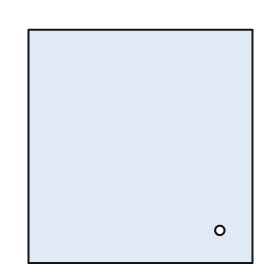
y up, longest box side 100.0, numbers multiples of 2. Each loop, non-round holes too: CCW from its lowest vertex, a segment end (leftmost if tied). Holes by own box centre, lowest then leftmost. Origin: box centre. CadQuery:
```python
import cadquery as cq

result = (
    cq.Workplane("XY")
    .moveTo(-48.0, -50.0)
    .lineTo(48.0, -50.0)
    .lineTo(48.0, 50.0)
    .lineTo(-48.0, 50.0)
    .close()
    .moveTo(34.0, -36.0)
    .circle(2.0)
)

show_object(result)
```